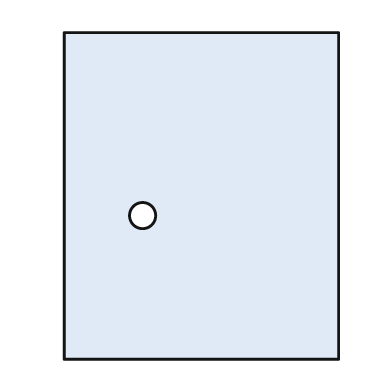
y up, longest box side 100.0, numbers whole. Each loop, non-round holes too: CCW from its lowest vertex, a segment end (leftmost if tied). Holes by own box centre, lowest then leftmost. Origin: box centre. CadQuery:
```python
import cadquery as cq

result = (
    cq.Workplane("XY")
    .moveTo(-42.0, -50.0)
    .lineTo(42.0, -50.0)
    .lineTo(42.0, 50.0)
    .lineTo(-42.0, 50.0)
    .close()
    .moveTo(-18.0, -6.0)
    .circle(4.0)
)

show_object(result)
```